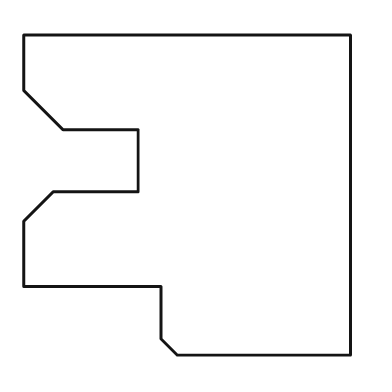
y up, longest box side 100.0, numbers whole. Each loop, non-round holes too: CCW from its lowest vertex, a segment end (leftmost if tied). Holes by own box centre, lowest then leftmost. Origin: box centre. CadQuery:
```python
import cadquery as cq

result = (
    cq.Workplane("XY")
    .moveTo(-3.0, -49.0)
    .lineTo(50.0, -49.0)
    .lineTo(50.0, 49.0)
    .lineTo(-50.0, 49.0)
    .lineTo(-50.0, 32.0)
    .lineTo(-38.0, 20.0)
    .lineTo(-15.0, 20.0)
    .lineTo(-15.0, 1.0)
    .lineTo(-41.0, 1.0)
    .lineTo(-50.0, -8.0)
    .lineTo(-50.0, -28.0)
    .lineTo(-8.0, -28.0)
    .lineTo(-8.0, -44.0)
    .close()
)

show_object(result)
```